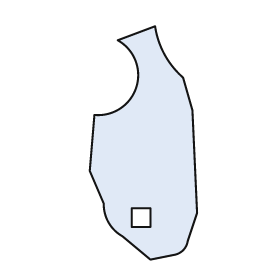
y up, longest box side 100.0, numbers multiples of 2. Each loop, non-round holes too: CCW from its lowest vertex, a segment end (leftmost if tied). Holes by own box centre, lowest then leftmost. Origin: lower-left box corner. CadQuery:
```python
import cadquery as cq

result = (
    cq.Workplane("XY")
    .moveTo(26.0, 0.0)
    .lineTo(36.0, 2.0)
    .threePointArc((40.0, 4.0), (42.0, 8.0))
    .lineTo(46.0, 20.0)
    .lineTo(44.0, 64.0)
    .lineTo(40.0, 78.0)
    .threePointArc((32.0, 88.0), (28.0, 100.0))
    .lineTo(12.0, 94.0)
    .threePointArc((20.0, 74.0), (2.0, 62.0))
    .lineTo(0.0, 38.0)
    .lineTo(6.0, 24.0)
    .threePointArc((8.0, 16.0), (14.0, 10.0))
    .close()
    .moveTo(18.0, 14.0)
    .lineTo(26.0, 14.0)
    .lineTo(26.0, 22.0)
    .lineTo(18.0, 22.0)
    .close()
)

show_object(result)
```